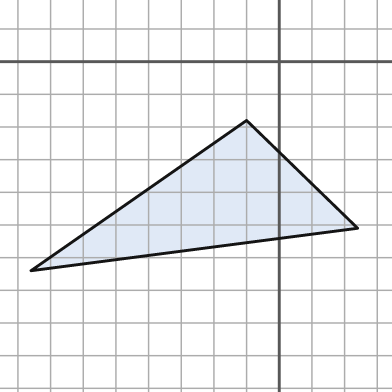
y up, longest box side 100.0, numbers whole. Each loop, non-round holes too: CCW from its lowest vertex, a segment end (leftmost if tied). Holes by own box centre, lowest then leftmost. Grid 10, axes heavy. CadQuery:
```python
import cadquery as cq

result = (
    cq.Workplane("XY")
    .moveTo(-76.0, -64.0)
    .lineTo(24.0, -51.0)
    .lineTo(-10.0, -18.0)
    .close()
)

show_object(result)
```